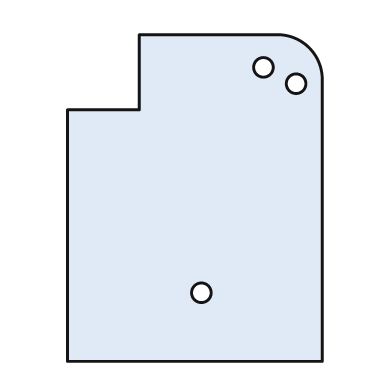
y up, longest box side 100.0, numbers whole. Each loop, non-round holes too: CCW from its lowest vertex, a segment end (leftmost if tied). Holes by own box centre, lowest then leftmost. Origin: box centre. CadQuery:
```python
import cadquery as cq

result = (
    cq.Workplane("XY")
    .moveTo(-39.0, -50.0)
    .lineTo(39.0, -50.0)
    .lineTo(39.0, 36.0)
    .threePointArc((35.0, 46.0), (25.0, 50.0))
    .lineTo(-17.0, 50.0)
    .lineTo(-17.0, 27.0)
    .lineTo(-39.0, 27.0)
    .close()
    .moveTo(2.0, -29.0)
    .circle(3.0)
    .moveTo(31.0, 35.0)
    .circle(3.0)
    .moveTo(21.0, 40.0)
    .circle(3.0)
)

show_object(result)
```